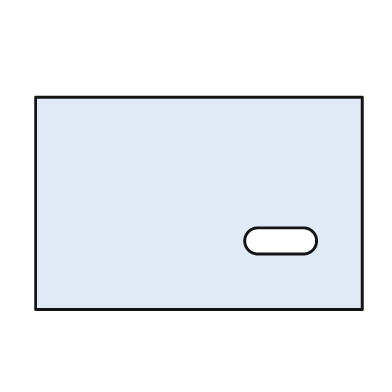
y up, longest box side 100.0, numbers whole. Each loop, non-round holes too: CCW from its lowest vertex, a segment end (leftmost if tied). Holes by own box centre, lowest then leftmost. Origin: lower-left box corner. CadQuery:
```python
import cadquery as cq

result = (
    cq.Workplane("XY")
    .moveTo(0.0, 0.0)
    .lineTo(100.0, 0.0)
    .lineTo(100.0, 65.0)
    .lineTo(0.0, 65.0)
    .close()
    .moveTo(68.0, 17.0)
    .lineTo(82.0, 17.0)
    .threePointArc((86.0, 21.0), (82.0, 25.0))
    .lineTo(68.0, 25.0)
    .threePointArc((64.0, 21.0), (68.0, 17.0))
    .close()
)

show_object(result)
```